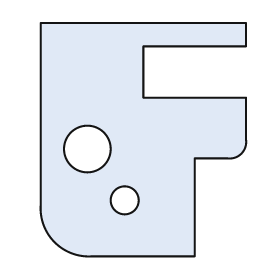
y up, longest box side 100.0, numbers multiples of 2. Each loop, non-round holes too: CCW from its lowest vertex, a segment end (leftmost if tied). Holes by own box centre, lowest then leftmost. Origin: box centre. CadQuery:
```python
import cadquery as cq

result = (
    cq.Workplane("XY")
    .moveTo(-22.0, -50.0)
    .lineTo(22.0, -50.0)
    .lineTo(22.0, -8.0)
    .lineTo(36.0, -8.0)
    .threePointArc((42.0, -6.0), (44.0, 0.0))
    .lineTo(44.0, 18.0)
    .lineTo(0.0, 18.0)
    .lineTo(0.0, 40.0)
    .lineTo(44.0, 40.0)
    .lineTo(44.0, 50.0)
    .lineTo(-44.0, 50.0)
    .lineTo(-44.0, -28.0)
    .threePointArc((-38.0, -44.0), (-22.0, -50.0))
    .close()
    .moveTo(-8.0, -26.0)
    .circle(6.0)
    .moveTo(-24.0, -4.0)
    .circle(10.0)
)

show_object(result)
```